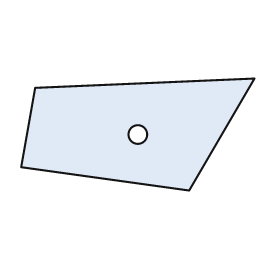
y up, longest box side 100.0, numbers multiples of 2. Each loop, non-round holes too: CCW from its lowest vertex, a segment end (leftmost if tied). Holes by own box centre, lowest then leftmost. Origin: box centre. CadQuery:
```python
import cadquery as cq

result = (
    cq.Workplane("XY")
    .moveTo(22.0, -24.0)
    .lineTo(50.0, 24.0)
    .lineTo(-44.0, 20.0)
    .lineTo(-50.0, -14.0)
    .close()
    .moveTo(0.0, 0.0)
    .circle(4.0)
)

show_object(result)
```